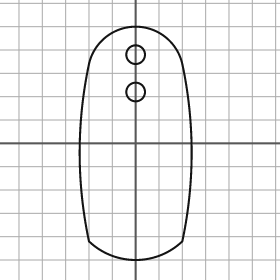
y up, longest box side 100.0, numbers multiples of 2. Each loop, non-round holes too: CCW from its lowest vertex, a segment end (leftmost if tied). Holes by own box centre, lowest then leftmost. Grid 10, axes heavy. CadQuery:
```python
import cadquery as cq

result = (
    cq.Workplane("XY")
    .moveTo(-20.0, -42.0)
    .threePointArc((0.0, -50.0), (20.0, -42.0))
    .threePointArc((24.0, -4.0), (20.0, 34.0))
    .threePointArc((0.0, 50.0), (-20.0, 34.0))
    .threePointArc((-24.0, -4.0), (-20.0, -42.0))
    .close()
    .moveTo(0.0, 22.0)
    .circle(4.0)
    .moveTo(0.0, 38.0)
    .circle(4.0)
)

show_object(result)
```